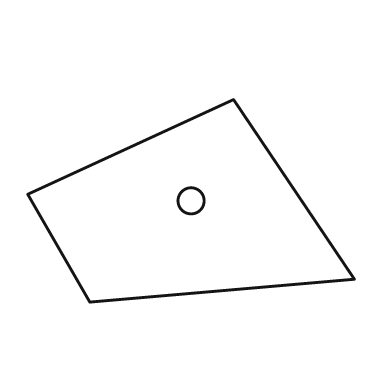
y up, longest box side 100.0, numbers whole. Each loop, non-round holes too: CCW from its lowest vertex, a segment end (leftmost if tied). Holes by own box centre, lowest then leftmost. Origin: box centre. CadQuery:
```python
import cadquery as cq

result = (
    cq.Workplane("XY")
    .moveTo(-31.0, -31.0)
    .lineTo(50.0, -24.0)
    .lineTo(13.0, 31.0)
    .lineTo(-50.0, 2.0)
    .close()
    .moveTo(0.0, 0.0)
    .circle(4.0)
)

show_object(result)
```